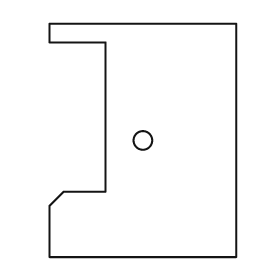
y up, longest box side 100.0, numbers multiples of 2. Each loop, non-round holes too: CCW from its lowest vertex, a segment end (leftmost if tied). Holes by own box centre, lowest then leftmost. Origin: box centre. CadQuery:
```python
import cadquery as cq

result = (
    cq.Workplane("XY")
    .moveTo(-40.0, -50.0)
    .lineTo(40.0, -50.0)
    .lineTo(40.0, 50.0)
    .lineTo(-40.0, 50.0)
    .lineTo(-40.0, 42.0)
    .lineTo(-16.0, 42.0)
    .lineTo(-16.0, -22.0)
    .lineTo(-34.0, -22.0)
    .lineTo(-40.0, -28.0)
    .close()
    .moveTo(0.0, 0.0)
    .circle(4.0)
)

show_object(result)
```